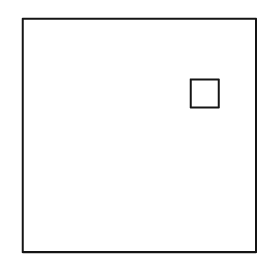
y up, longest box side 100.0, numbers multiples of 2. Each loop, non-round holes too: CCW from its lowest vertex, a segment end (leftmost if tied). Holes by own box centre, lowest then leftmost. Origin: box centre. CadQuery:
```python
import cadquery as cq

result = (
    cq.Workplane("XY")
    .moveTo(-50.0, -50.0)
    .lineTo(50.0, -50.0)
    .lineTo(50.0, 50.0)
    .lineTo(-50.0, 50.0)
    .close()
    .moveTo(22.0, 12.0)
    .lineTo(34.0, 12.0)
    .lineTo(34.0, 24.0)
    .lineTo(22.0, 24.0)
    .close()
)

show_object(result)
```